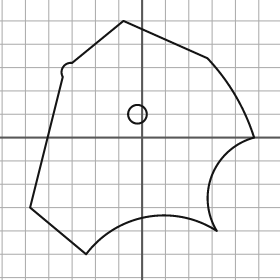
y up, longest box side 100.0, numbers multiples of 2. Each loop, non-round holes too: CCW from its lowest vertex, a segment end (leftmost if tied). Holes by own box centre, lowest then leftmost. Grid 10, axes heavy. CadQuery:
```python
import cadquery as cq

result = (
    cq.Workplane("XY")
    .moveTo(-24.0, -50.0)
    .threePointArc((2.0, -34.0), (32.0, -40.0))
    .threePointArc((30.0, -16.0), (48.0, 0.0))
    .threePointArc((40.0, 18.0), (28.0, 34.0))
    .lineTo(-8.0, 50.0)
    .lineTo(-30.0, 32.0)
    .threePointArc((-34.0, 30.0), (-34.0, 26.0))
    .lineTo(-48.0, -30.0)
    .close()
    .moveTo(-2.0, 10.0)
    .circle(4.0)
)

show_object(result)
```